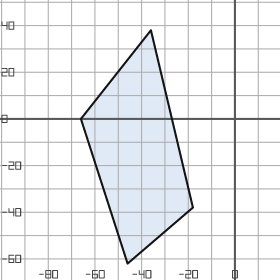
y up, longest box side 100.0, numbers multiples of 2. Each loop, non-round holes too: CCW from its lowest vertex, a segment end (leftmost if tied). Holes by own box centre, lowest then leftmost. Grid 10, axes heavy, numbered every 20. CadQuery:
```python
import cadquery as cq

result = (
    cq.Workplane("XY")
    .moveTo(-46.0, -62.0)
    .lineTo(-18.0, -38.0)
    .lineTo(-36.0, 38.0)
    .lineTo(-66.0, 0.0)
    .close()
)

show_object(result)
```